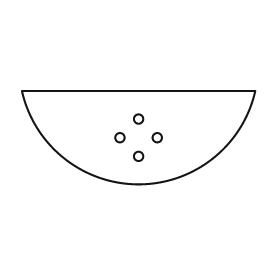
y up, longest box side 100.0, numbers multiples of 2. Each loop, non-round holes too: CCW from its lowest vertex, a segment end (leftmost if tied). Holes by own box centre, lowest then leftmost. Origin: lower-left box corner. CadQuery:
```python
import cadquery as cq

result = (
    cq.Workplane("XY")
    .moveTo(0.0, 40.0)
    .threePointArc((50.0, 0.0), (100.0, 40.0))
    .close()
    .moveTo(50.0, 12.0)
    .circle(2.0)
    .moveTo(42.0, 20.0)
    .circle(2.0)
    .moveTo(58.0, 20.0)
    .circle(2.0)
    .moveTo(50.0, 28.0)
    .circle(2.0)
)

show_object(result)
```